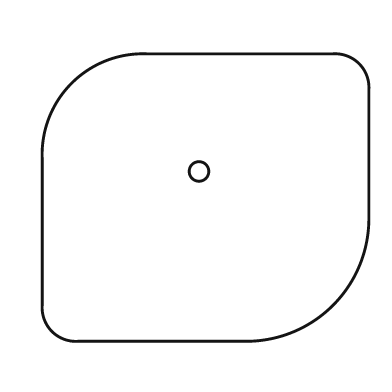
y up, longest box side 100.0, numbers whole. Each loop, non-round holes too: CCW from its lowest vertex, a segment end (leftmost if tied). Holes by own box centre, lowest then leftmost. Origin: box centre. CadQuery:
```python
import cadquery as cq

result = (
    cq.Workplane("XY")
    .moveTo(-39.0, -44.0)
    .lineTo(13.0, -44.0)
    .threePointArc((39.0, -33.0), (50.0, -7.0))
    .lineTo(50.0, 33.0)
    .threePointArc((47.0, 41.0), (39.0, 44.0))
    .lineTo(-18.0, 44.0)
    .threePointArc((-41.0, 35.0), (-50.0, 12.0))
    .lineTo(-50.0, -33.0)
    .threePointArc((-47.0, -41.0), (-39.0, -44.0))
    .close()
    .moveTo(-2.0, 8.0)
    .circle(3.0)
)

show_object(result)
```